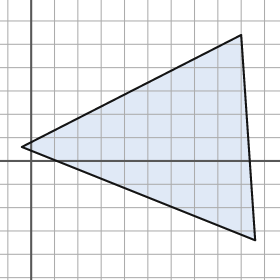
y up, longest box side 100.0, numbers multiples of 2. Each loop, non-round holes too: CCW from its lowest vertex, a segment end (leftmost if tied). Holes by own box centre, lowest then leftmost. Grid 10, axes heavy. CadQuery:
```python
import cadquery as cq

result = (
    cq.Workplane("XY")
    .moveTo(96.0, -34.0)
    .lineTo(90.0, 54.0)
    .lineTo(-4.0, 6.0)
    .close()
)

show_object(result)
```